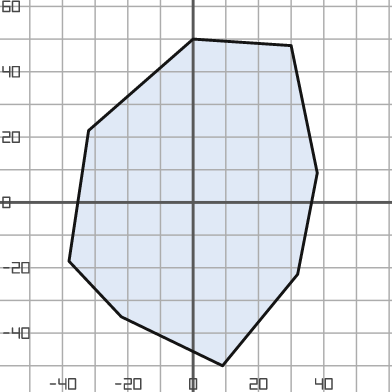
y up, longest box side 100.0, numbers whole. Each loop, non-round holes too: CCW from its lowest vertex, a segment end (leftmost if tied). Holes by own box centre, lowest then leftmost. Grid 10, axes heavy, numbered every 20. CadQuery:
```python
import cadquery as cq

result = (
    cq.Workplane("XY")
    .moveTo(9.0, -50.0)
    .lineTo(32.0, -22.0)
    .lineTo(38.0, 9.0)
    .lineTo(30.0, 48.0)
    .lineTo(0.0, 50.0)
    .lineTo(-32.0, 22.0)
    .lineTo(-38.0, -18.0)
    .lineTo(-22.0, -35.0)
    .close()
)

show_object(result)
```